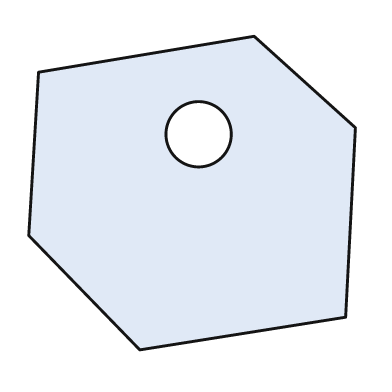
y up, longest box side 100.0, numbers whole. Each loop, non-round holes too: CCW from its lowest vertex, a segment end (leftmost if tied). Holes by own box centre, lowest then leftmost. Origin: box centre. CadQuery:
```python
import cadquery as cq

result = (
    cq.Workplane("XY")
    .moveTo(-16.0, -48.0)
    .lineTo(47.0, -38.0)
    .lineTo(50.0, 20.0)
    .lineTo(19.0, 48.0)
    .lineTo(-47.0, 37.0)
    .lineTo(-50.0, -13.0)
    .close()
    .moveTo(2.0, 18.0)
    .circle(10.0)
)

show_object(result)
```